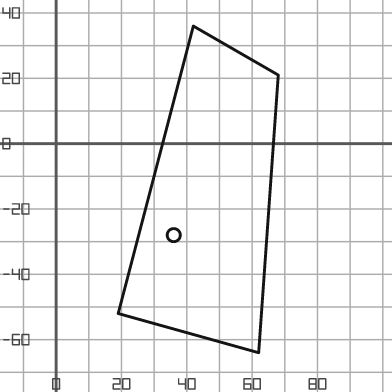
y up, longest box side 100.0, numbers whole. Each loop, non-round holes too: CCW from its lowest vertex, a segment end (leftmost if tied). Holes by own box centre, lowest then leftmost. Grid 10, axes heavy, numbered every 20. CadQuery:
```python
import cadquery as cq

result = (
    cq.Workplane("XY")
    .moveTo(62.0, -64.0)
    .lineTo(68.0, 21.0)
    .lineTo(42.0, 36.0)
    .lineTo(19.0, -52.0)
    .close()
    .moveTo(36.0, -28.0)
    .circle(2.0)
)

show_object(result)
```